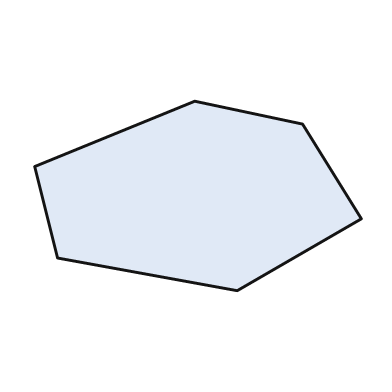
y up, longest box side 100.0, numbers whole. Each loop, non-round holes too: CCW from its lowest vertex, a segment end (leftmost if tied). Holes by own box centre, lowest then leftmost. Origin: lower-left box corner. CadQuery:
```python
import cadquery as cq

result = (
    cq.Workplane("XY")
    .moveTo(62.0, 0.0)
    .lineTo(100.0, 22.0)
    .lineTo(82.0, 51.0)
    .lineTo(49.0, 58.0)
    .lineTo(0.0, 38.0)
    .lineTo(7.0, 10.0)
    .close()
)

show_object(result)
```